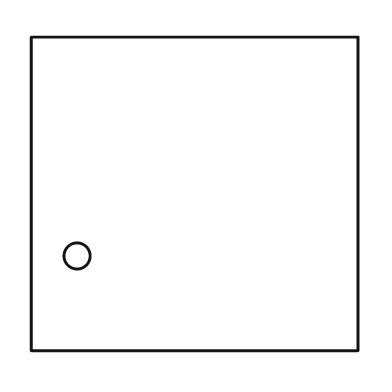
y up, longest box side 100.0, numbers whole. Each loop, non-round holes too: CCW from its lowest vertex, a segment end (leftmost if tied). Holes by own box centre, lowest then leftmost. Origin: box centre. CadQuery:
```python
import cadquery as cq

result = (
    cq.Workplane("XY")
    .moveTo(-50.0, -48.0)
    .lineTo(50.0, -48.0)
    .lineTo(50.0, 48.0)
    .lineTo(-50.0, 48.0)
    .close()
    .moveTo(-36.0, -19.0)
    .circle(4.0)
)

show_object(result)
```